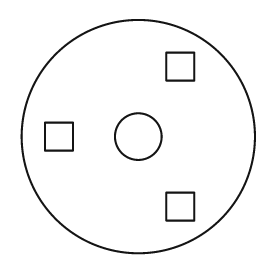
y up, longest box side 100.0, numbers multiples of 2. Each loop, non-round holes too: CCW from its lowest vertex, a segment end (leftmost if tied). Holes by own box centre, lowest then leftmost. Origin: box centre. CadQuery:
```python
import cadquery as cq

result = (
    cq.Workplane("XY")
    .moveTo(0.0, 0.0)
    .circle(50.0)
    .moveTo(12.0, -36.0)
    .lineTo(24.0, -36.0)
    .lineTo(24.0, -24.0)
    .lineTo(12.0, -24.0)
    .close()
    .moveTo(-40.0, -6.0)
    .lineTo(-28.0, -6.0)
    .lineTo(-28.0, 6.0)
    .lineTo(-40.0, 6.0)
    .close()
    .moveTo(0.0, 0.0)
    .circle(10.0)
    .moveTo(12.0, 24.0)
    .lineTo(24.0, 24.0)
    .lineTo(24.0, 36.0)
    .lineTo(12.0, 36.0)
    .close()
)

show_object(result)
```